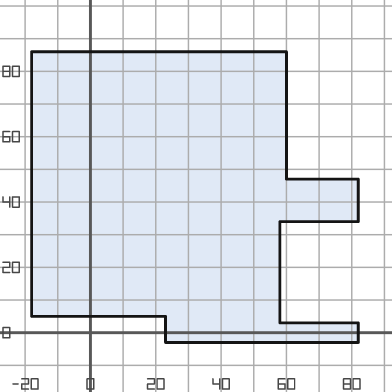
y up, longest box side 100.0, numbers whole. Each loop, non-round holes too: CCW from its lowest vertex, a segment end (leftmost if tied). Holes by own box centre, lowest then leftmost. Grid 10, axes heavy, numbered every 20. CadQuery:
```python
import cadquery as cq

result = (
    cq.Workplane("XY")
    .moveTo(23.0, -3.0)
    .lineTo(82.0, -3.0)
    .lineTo(82.0, 3.0)
    .lineTo(58.0, 3.0)
    .lineTo(58.0, 34.0)
    .lineTo(82.0, 34.0)
    .lineTo(82.0, 47.0)
    .lineTo(60.0, 47.0)
    .lineTo(60.0, 86.0)
    .lineTo(-18.0, 86.0)
    .lineTo(-18.0, 5.0)
    .lineTo(23.0, 5.0)
    .close()
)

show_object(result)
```